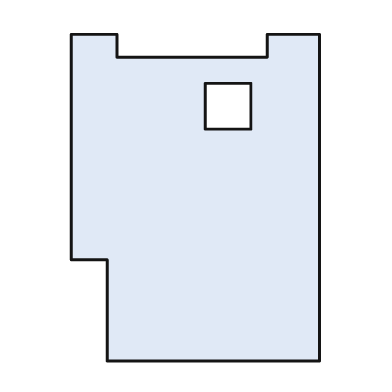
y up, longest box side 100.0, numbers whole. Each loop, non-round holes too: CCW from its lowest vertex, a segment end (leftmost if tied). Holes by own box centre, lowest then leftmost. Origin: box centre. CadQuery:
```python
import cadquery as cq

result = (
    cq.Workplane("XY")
    .moveTo(-27.0, -50.0)
    .lineTo(38.0, -50.0)
    .lineTo(38.0, 50.0)
    .lineTo(22.0, 50.0)
    .lineTo(22.0, 43.0)
    .lineTo(-24.0, 43.0)
    .lineTo(-24.0, 50.0)
    .lineTo(-38.0, 50.0)
    .lineTo(-38.0, -19.0)
    .lineTo(-27.0, -19.0)
    .close()
    .moveTo(3.0, 21.0)
    .lineTo(17.0, 21.0)
    .lineTo(17.0, 35.0)
    .lineTo(3.0, 35.0)
    .close()
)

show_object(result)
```